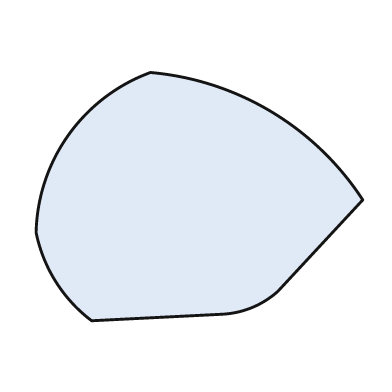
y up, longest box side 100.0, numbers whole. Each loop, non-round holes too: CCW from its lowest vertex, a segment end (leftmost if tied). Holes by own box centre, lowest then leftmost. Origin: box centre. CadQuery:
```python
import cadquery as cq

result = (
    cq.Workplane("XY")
    .moveTo(-33.0, -38.0)
    .lineTo(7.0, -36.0)
    .threePointArc((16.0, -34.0), (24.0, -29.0))
    .lineTo(50.0, -1.0)
    .threePointArc((22.0, 26.0), (-15.0, 38.0))
    .threePointArc((-40.0, 19.0), (-50.0, -11.0))
    .threePointArc((-44.0, -26.0), (-33.0, -38.0))
    .close()
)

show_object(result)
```